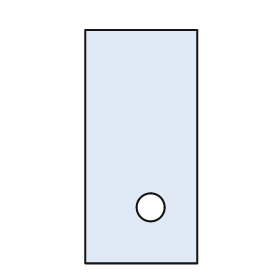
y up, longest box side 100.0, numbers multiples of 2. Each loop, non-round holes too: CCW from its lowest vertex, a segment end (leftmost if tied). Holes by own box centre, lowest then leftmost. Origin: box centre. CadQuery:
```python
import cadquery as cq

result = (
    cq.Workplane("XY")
    .moveTo(-24.0, -50.0)
    .lineTo(24.0, -50.0)
    .lineTo(24.0, 50.0)
    .lineTo(-24.0, 50.0)
    .close()
    .moveTo(4.0, -26.0)
    .circle(6.0)
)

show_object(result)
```